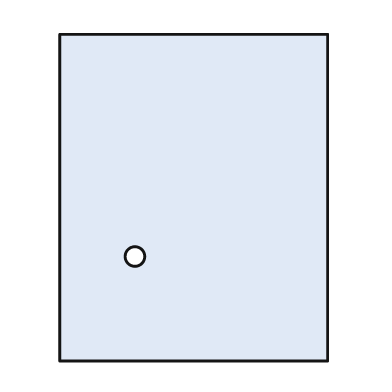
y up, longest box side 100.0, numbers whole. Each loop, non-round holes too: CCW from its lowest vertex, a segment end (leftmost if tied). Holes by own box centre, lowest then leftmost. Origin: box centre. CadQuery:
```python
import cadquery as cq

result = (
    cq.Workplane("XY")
    .moveTo(-41.0, -50.0)
    .lineTo(41.0, -50.0)
    .lineTo(41.0, 50.0)
    .lineTo(-41.0, 50.0)
    .close()
    .moveTo(-18.0, -18.0)
    .circle(3.0)
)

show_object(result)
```